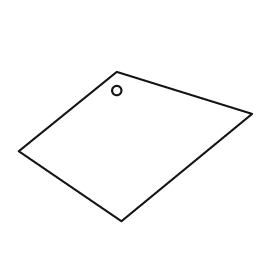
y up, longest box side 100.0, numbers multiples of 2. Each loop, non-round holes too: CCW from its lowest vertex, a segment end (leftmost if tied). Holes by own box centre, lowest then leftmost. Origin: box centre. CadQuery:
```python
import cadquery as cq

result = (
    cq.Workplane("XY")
    .moveTo(-6.0, -32.0)
    .lineTo(50.0, 14.0)
    .lineTo(-8.0, 32.0)
    .lineTo(-50.0, -2.0)
    .close()
    .moveTo(-8.0, 24.0)
    .circle(2.0)
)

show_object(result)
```